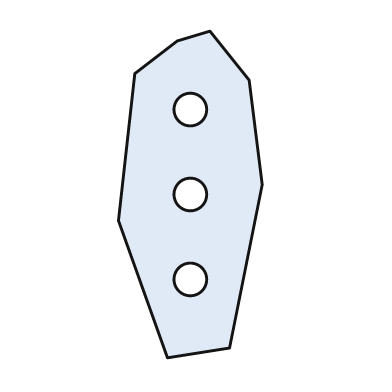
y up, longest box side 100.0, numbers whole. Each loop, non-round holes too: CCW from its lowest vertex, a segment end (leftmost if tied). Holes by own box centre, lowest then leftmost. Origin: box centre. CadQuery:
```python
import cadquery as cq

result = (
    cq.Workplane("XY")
    .moveTo(-7.0, -50.0)
    .lineTo(12.0, -47.0)
    .lineTo(22.0, 3.0)
    .lineTo(18.0, 35.0)
    .lineTo(6.0, 50.0)
    .lineTo(-4.0, 47.0)
    .lineTo(-17.0, 37.0)
    .lineTo(-22.0, -8.0)
    .close()
    .moveTo(0.0, -26.0)
    .circle(5.0)
    .moveTo(0.0, 0.0)
    .circle(5.0)
    .moveTo(0.0, 26.0)
    .circle(5.0)
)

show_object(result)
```